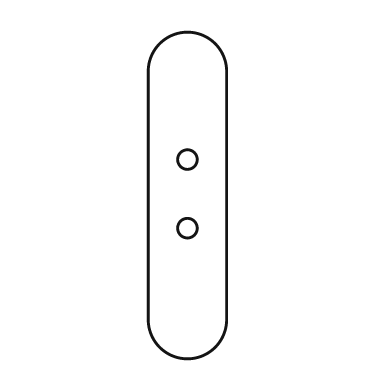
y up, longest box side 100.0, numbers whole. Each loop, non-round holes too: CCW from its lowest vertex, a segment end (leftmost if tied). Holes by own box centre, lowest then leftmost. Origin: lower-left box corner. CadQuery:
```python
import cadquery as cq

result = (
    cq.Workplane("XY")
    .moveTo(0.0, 12.0)
    .threePointArc((12.0, 0.0), (24.0, 12.0))
    .lineTo(24.0, 88.0)
    .threePointArc((12.0, 100.0), (0.0, 88.0))
    .close()
    .moveTo(12.0, 40.0)
    .circle(3.0)
    .moveTo(12.0, 61.0)
    .circle(3.0)
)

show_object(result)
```